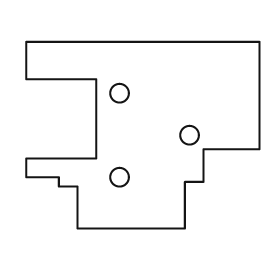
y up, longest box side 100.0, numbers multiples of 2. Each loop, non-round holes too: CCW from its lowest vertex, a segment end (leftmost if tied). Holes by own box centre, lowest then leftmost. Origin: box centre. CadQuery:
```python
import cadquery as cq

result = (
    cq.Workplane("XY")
    .moveTo(-28.0, -40.0)
    .lineTo(18.0, -40.0)
    .lineTo(18.0, -20.0)
    .lineTo(26.0, -20.0)
    .lineTo(26.0, -6.0)
    .lineTo(50.0, -6.0)
    .lineTo(50.0, 40.0)
    .lineTo(-50.0, 40.0)
    .lineTo(-50.0, 24.0)
    .lineTo(-20.0, 24.0)
    .lineTo(-20.0, -10.0)
    .lineTo(-50.0, -10.0)
    .lineTo(-50.0, -18.0)
    .lineTo(-36.0, -18.0)
    .lineTo(-36.0, -22.0)
    .lineTo(-28.0, -22.0)
    .close()
    .moveTo(-10.0, -18.0)
    .circle(4.0)
    .moveTo(20.0, 0.0)
    .circle(4.0)
    .moveTo(-10.0, 18.0)
    .circle(4.0)
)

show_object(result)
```